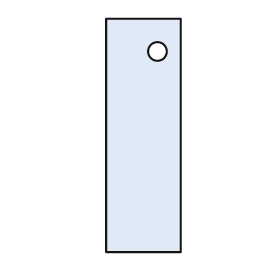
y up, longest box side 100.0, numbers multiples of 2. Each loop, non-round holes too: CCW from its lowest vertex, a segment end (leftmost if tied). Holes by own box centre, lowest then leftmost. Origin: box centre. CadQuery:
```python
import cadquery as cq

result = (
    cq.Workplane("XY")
    .moveTo(-16.0, -50.0)
    .lineTo(16.0, -50.0)
    .lineTo(16.0, 50.0)
    .lineTo(-16.0, 50.0)
    .close()
    .moveTo(6.0, 36.0)
    .circle(4.0)
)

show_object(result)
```